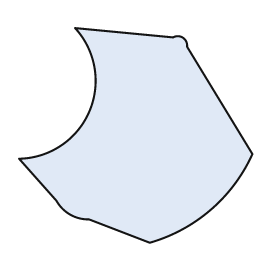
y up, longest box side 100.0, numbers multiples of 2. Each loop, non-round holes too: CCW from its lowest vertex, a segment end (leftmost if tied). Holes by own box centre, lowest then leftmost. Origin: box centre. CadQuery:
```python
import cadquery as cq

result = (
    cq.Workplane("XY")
    .moveTo(6.0, -46.0)
    .threePointArc((32.0, -32.0), (50.0, -8.0))
    .lineTo(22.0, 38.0)
    .threePointArc((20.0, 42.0), (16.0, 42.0))
    .lineTo(-26.0, 46.0)
    .threePointArc((-20.0, 10.0), (-50.0, -10.0))
    .lineTo(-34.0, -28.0)
    .threePointArc((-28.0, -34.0), (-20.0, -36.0))
    .close()
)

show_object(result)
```